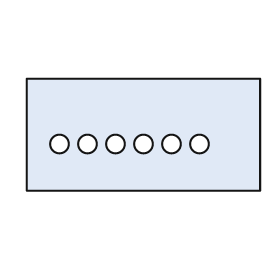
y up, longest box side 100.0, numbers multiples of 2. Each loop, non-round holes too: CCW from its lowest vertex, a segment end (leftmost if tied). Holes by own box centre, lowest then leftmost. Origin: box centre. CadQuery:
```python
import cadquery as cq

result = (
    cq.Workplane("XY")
    .moveTo(-50.0, -24.0)
    .lineTo(50.0, -24.0)
    .lineTo(50.0, 24.0)
    .lineTo(-50.0, 24.0)
    .close()
    .moveTo(-36.0, -4.0)
    .circle(4.0)
    .moveTo(-24.0, -4.0)
    .circle(4.0)
    .moveTo(-12.0, -4.0)
    .circle(4.0)
    .moveTo(0.0, -4.0)
    .circle(4.0)
    .moveTo(12.0, -4.0)
    .circle(4.0)
    .moveTo(24.0, -4.0)
    .circle(4.0)
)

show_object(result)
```